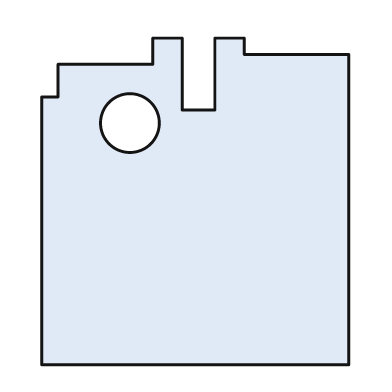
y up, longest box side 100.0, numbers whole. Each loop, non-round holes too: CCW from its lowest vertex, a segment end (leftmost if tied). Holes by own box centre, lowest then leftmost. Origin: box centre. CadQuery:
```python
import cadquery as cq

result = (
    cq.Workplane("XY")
    .moveTo(-47.0, -50.0)
    .lineTo(47.0, -50.0)
    .lineTo(47.0, 45.0)
    .lineTo(15.0, 45.0)
    .lineTo(15.0, 50.0)
    .lineTo(6.0, 50.0)
    .lineTo(6.0, 28.0)
    .lineTo(-4.0, 28.0)
    .lineTo(-4.0, 50.0)
    .lineTo(-13.0, 50.0)
    .lineTo(-13.0, 42.0)
    .lineTo(-42.0, 42.0)
    .lineTo(-42.0, 32.0)
    .lineTo(-47.0, 32.0)
    .close()
    .moveTo(-20.0, 24.0)
    .circle(9.0)
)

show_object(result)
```